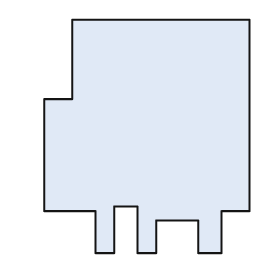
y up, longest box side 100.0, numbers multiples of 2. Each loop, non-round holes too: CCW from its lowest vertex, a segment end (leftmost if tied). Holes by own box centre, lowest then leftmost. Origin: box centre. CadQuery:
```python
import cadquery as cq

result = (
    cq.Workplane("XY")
    .moveTo(-22.0, -50.0)
    .lineTo(-14.0, -50.0)
    .lineTo(-14.0, -30.0)
    .lineTo(-4.0, -30.0)
    .lineTo(-4.0, -50.0)
    .lineTo(4.0, -50.0)
    .lineTo(4.0, -36.0)
    .lineTo(22.0, -36.0)
    .lineTo(22.0, -50.0)
    .lineTo(32.0, -50.0)
    .lineTo(32.0, -32.0)
    .lineTo(44.0, -32.0)
    .lineTo(44.0, 50.0)
    .lineTo(-32.0, 50.0)
    .lineTo(-32.0, 16.0)
    .lineTo(-44.0, 16.0)
    .lineTo(-44.0, -32.0)
    .lineTo(-22.0, -32.0)
    .close()
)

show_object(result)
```